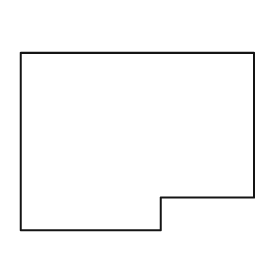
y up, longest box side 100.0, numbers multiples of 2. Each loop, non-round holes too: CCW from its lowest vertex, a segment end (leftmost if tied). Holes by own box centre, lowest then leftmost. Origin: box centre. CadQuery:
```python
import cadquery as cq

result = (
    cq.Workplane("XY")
    .moveTo(-50.0, -38.0)
    .lineTo(10.0, -38.0)
    .lineTo(10.0, -24.0)
    .lineTo(50.0, -24.0)
    .lineTo(50.0, 38.0)
    .lineTo(-50.0, 38.0)
    .close()
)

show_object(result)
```